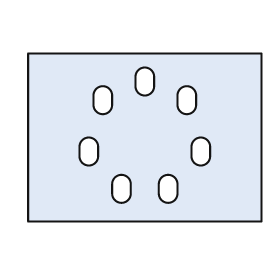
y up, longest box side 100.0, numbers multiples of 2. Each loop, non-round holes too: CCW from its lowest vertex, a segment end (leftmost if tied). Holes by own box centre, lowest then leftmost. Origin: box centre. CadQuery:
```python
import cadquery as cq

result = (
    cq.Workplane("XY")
    .moveTo(-50.0, -36.0)
    .lineTo(50.0, -36.0)
    .lineTo(50.0, 36.0)
    .lineTo(-50.0, 36.0)
    .close()
    .moveTo(-14.0, -24.0)
    .threePointArc((-10.0, -28.0), (-6.0, -24.0))
    .lineTo(-6.0, -20.0)
    .threePointArc((-10.0, -16.0), (-14.0, -20.0))
    .close()
    .moveTo(6.0, -24.0)
    .threePointArc((10.0, -28.0), (14.0, -24.0))
    .lineTo(14.0, -20.0)
    .threePointArc((10.0, -16.0), (6.0, -20.0))
    .close()
    .moveTo(-28.0, -8.0)
    .threePointArc((-24.0, -12.0), (-20.0, -8.0))
    .lineTo(-20.0, -4.0)
    .threePointArc((-24.0, 0.0), (-28.0, -4.0))
    .close()
    .moveTo(20.0, -8.0)
    .threePointArc((24.0, -12.0), (28.0, -8.0))
    .lineTo(28.0, -4.0)
    .threePointArc((24.0, 0.0), (20.0, -4.0))
    .close()
    .moveTo(-22.0, 14.0)
    .threePointArc((-18.0, 10.0), (-14.0, 14.0))
    .lineTo(-14.0, 18.0)
    .threePointArc((-18.0, 22.0), (-22.0, 18.0))
    .close()
    .moveTo(14.0, 14.0)
    .threePointArc((18.0, 10.0), (22.0, 14.0))
    .lineTo(22.0, 18.0)
    .threePointArc((18.0, 22.0), (14.0, 18.0))
    .close()
    .moveTo(-4.0, 22.0)
    .threePointArc((0.0, 18.0), (4.0, 22.0))
    .lineTo(4.0, 26.0)
    .threePointArc((0.0, 30.0), (-4.0, 26.0))
    .close()
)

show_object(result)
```